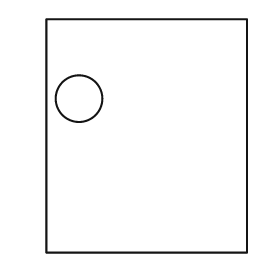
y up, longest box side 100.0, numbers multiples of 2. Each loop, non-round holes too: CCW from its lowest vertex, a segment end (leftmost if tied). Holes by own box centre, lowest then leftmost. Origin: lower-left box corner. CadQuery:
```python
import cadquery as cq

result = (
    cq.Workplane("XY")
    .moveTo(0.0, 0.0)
    .lineTo(86.0, 0.0)
    .lineTo(86.0, 100.0)
    .lineTo(0.0, 100.0)
    .close()
    .moveTo(14.0, 66.0)
    .circle(10.0)
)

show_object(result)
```